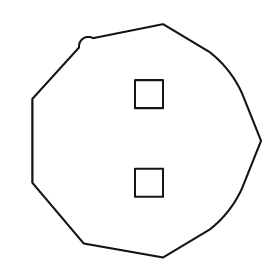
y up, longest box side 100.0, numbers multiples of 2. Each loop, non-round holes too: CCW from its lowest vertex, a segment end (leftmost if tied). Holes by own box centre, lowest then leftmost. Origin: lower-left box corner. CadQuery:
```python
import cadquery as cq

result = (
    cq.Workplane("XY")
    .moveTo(56.0, 0.0)
    .lineTo(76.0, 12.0)
    .threePointArc((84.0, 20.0), (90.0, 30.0))
    .lineTo(98.0, 50.0)
    .lineTo(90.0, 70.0)
    .threePointArc((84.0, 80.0), (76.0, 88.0))
    .lineTo(56.0, 100.0)
    .lineTo(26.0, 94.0)
    .threePointArc((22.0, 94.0), (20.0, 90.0))
    .lineTo(0.0, 68.0)
    .lineTo(0.0, 32.0)
    .lineTo(22.0, 6.0)
    .close()
    .moveTo(44.0, 26.0)
    .lineTo(56.0, 26.0)
    .lineTo(56.0, 38.0)
    .lineTo(44.0, 38.0)
    .close()
    .moveTo(44.0, 64.0)
    .lineTo(56.0, 64.0)
    .lineTo(56.0, 76.0)
    .lineTo(44.0, 76.0)
    .close()
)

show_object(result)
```